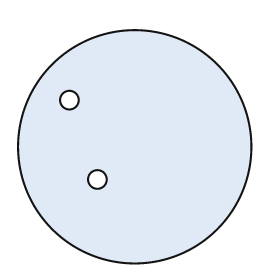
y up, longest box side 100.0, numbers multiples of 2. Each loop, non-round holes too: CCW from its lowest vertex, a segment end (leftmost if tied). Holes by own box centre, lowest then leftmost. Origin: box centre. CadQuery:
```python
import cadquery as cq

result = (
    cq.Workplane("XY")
    .moveTo(0.0, 0.0)
    .circle(50.0)
    .moveTo(-16.0, -14.0)
    .circle(4.0)
    .moveTo(-28.0, 20.0)
    .circle(4.0)
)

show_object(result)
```